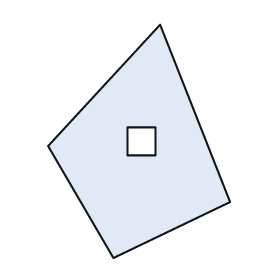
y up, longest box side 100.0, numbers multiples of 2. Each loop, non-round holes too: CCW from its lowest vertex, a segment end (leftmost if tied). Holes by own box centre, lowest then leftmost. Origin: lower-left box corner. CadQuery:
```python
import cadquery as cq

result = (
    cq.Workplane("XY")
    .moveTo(28.0, 0.0)
    .lineTo(78.0, 24.0)
    .lineTo(48.0, 100.0)
    .lineTo(0.0, 48.0)
    .close()
    .moveTo(34.0, 44.0)
    .lineTo(46.0, 44.0)
    .lineTo(46.0, 56.0)
    .lineTo(34.0, 56.0)
    .close()
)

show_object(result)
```